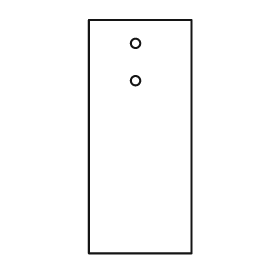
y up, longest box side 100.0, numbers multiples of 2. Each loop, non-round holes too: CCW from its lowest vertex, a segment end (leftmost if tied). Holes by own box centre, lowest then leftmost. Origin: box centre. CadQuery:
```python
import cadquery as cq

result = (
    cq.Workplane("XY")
    .moveTo(-22.0, -50.0)
    .lineTo(22.0, -50.0)
    .lineTo(22.0, 50.0)
    .lineTo(-22.0, 50.0)
    .close()
    .moveTo(-2.0, 24.0)
    .circle(2.0)
    .moveTo(-2.0, 40.0)
    .circle(2.0)
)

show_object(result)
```